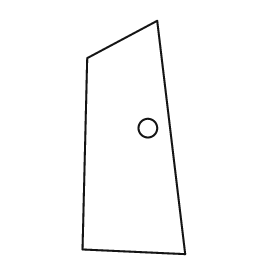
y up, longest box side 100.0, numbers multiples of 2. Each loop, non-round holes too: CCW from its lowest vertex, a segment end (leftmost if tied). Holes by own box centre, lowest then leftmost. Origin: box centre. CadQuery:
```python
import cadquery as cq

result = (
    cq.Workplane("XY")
    .moveTo(22.0, -50.0)
    .lineTo(10.0, 50.0)
    .lineTo(-20.0, 34.0)
    .lineTo(-22.0, -48.0)
    .close()
    .moveTo(6.0, 4.0)
    .circle(4.0)
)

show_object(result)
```